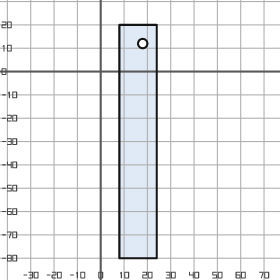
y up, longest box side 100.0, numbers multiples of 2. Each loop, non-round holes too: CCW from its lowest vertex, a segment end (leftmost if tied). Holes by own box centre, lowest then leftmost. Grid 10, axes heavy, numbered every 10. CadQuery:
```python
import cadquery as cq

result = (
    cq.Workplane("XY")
    .moveTo(8.0, -80.0)
    .lineTo(24.0, -80.0)
    .lineTo(24.0, 20.0)
    .lineTo(8.0, 20.0)
    .close()
    .moveTo(18.0, 12.0)
    .circle(2.0)
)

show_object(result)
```